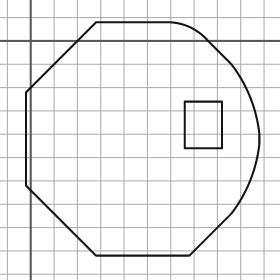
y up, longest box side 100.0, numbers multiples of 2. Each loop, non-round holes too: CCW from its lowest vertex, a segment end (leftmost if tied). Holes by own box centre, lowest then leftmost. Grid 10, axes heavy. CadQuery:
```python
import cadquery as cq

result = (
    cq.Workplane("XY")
    .moveTo(28.0, -92.0)
    .lineTo(68.0, -92.0)
    .lineTo(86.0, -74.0)
    .threePointArc((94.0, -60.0), (98.0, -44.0))
    .lineTo(98.0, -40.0)
    .threePointArc((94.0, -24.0), (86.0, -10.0))
    .lineTo(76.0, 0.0)
    .threePointArc((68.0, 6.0), (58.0, 8.0))
    .lineTo(28.0, 8.0)
    .lineTo(-2.0, -22.0)
    .lineTo(-2.0, -62.0)
    .close()
    .moveTo(66.0, -46.0)
    .lineTo(82.0, -46.0)
    .lineTo(82.0, -26.0)
    .lineTo(66.0, -26.0)
    .close()
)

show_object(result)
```